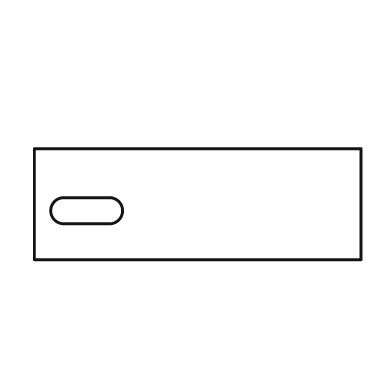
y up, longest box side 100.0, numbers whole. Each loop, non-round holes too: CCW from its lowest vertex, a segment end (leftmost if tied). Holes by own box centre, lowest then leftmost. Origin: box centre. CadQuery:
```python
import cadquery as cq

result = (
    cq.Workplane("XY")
    .moveTo(-50.0, -17.0)
    .lineTo(50.0, -17.0)
    .lineTo(50.0, 17.0)
    .lineTo(-50.0, 17.0)
    .close()
    .moveTo(-41.0, -6.0)
    .lineTo(-27.0, -6.0)
    .threePointArc((-23.0, -2.0), (-27.0, 2.0))
    .lineTo(-41.0, 2.0)
    .threePointArc((-45.0, -2.0), (-41.0, -6.0))
    .close()
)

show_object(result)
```